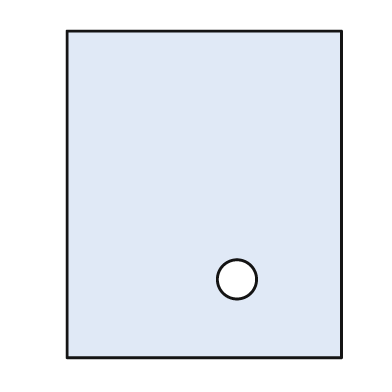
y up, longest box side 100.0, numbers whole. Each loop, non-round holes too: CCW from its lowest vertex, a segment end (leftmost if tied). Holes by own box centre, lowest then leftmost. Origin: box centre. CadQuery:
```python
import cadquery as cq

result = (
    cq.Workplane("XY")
    .moveTo(-42.0, -50.0)
    .lineTo(42.0, -50.0)
    .lineTo(42.0, 50.0)
    .lineTo(-42.0, 50.0)
    .close()
    .moveTo(10.0, -26.0)
    .circle(6.0)
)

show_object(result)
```